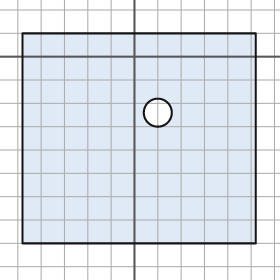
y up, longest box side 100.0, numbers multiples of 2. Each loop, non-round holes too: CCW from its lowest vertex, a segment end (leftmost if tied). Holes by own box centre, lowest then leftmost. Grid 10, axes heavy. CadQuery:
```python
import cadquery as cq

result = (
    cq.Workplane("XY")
    .moveTo(-48.0, -80.0)
    .lineTo(52.0, -80.0)
    .lineTo(52.0, 10.0)
    .lineTo(-48.0, 10.0)
    .close()
    .moveTo(10.0, -24.0)
    .circle(6.0)
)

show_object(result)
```